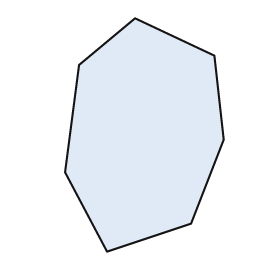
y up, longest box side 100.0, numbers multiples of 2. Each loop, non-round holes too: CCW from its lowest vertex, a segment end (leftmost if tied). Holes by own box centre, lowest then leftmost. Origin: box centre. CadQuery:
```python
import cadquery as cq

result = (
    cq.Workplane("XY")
    .moveTo(-16.0, -50.0)
    .lineTo(20.0, -38.0)
    .lineTo(34.0, -2.0)
    .lineTo(30.0, 34.0)
    .lineTo(-4.0, 50.0)
    .lineTo(-28.0, 30.0)
    .lineTo(-34.0, -16.0)
    .close()
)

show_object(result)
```